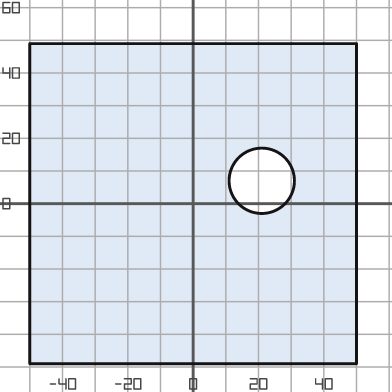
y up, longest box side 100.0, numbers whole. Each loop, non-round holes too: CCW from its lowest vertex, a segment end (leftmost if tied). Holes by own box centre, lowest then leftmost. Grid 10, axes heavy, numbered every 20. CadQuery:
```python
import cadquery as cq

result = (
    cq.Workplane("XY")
    .moveTo(-50.0, -49.0)
    .lineTo(50.0, -49.0)
    .lineTo(50.0, 49.0)
    .lineTo(-50.0, 49.0)
    .close()
    .moveTo(21.0, 7.0)
    .circle(10.0)
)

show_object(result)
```